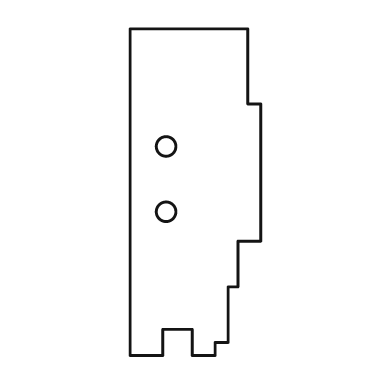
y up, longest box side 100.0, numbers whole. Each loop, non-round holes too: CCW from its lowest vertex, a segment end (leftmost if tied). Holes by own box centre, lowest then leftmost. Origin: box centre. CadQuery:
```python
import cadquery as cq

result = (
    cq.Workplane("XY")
    .moveTo(-20.0, -50.0)
    .lineTo(-10.0, -50.0)
    .lineTo(-10.0, -42.0)
    .lineTo(-1.0, -42.0)
    .lineTo(-1.0, -50.0)
    .lineTo(6.0, -50.0)
    .lineTo(6.0, -46.0)
    .lineTo(10.0, -46.0)
    .lineTo(10.0, -29.0)
    .lineTo(13.0, -29.0)
    .lineTo(13.0, -15.0)
    .lineTo(20.0, -15.0)
    .lineTo(20.0, 27.0)
    .lineTo(16.0, 27.0)
    .lineTo(16.0, 50.0)
    .lineTo(-20.0, 50.0)
    .close()
    .moveTo(-9.0, -6.0)
    .circle(3.0)
    .moveTo(-9.0, 14.0)
    .circle(3.0)
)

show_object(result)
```